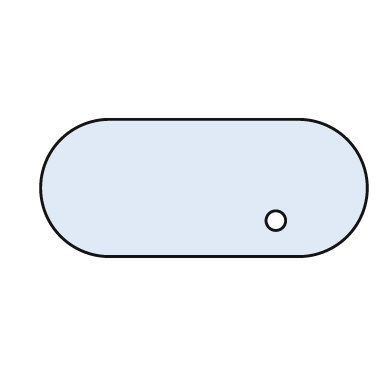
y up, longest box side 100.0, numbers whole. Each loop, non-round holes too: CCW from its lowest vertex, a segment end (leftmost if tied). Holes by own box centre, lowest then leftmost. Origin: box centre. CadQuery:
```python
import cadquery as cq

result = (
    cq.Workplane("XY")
    .moveTo(-29.0, -21.0)
    .lineTo(29.0, -21.0)
    .threePointArc((50.0, 0.0), (29.0, 21.0))
    .lineTo(-29.0, 21.0)
    .threePointArc((-50.0, 0.0), (-29.0, -21.0))
    .close()
    .moveTo(22.0, -10.0)
    .circle(3.0)
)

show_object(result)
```